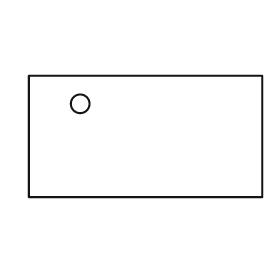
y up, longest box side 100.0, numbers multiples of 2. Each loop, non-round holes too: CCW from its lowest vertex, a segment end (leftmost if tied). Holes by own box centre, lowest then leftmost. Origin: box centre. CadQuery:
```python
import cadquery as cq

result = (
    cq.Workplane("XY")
    .moveTo(-50.0, -26.0)
    .lineTo(50.0, -26.0)
    .lineTo(50.0, 26.0)
    .lineTo(-50.0, 26.0)
    .close()
    .moveTo(-28.0, 14.0)
    .circle(4.0)
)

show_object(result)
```